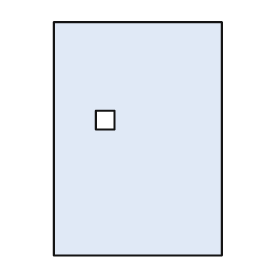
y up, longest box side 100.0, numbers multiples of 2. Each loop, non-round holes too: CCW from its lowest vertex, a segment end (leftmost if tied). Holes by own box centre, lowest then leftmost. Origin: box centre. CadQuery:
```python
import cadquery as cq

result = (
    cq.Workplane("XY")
    .moveTo(-36.0, -50.0)
    .lineTo(36.0, -50.0)
    .lineTo(36.0, 50.0)
    .lineTo(-36.0, 50.0)
    .close()
    .moveTo(-18.0, 4.0)
    .lineTo(-10.0, 4.0)
    .lineTo(-10.0, 12.0)
    .lineTo(-18.0, 12.0)
    .close()
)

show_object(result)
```